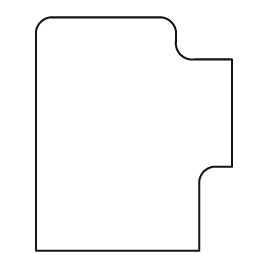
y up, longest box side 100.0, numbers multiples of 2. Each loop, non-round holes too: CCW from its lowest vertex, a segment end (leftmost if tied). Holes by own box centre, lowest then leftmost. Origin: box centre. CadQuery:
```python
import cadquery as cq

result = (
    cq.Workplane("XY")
    .moveTo(-42.0, -50.0)
    .lineTo(28.0, -50.0)
    .lineTo(28.0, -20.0)
    .threePointArc((30.0, -16.0), (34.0, -14.0))
    .lineTo(42.0, -14.0)
    .lineTo(42.0, 32.0)
    .lineTo(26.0, 32.0)
    .threePointArc((20.0, 34.0), (18.0, 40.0))
    .lineTo(18.0, 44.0)
    .threePointArc((16.0, 48.0), (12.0, 50.0))
    .lineTo(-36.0, 50.0)
    .threePointArc((-40.0, 48.0), (-42.0, 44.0))
    .close()
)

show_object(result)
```